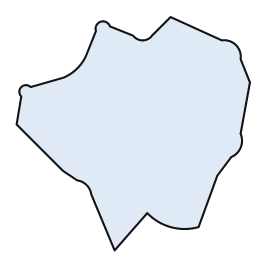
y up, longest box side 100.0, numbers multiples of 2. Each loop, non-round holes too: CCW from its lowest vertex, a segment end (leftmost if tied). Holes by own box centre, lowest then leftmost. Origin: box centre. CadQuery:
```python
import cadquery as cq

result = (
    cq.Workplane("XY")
    .moveTo(-8.0, -50.0)
    .lineTo(6.0, -34.0)
    .threePointArc((16.0, -40.0), (28.0, -40.0))
    .lineTo(36.0, -18.0)
    .lineTo(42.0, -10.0)
    .threePointArc((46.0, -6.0), (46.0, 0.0))
    .lineTo(50.0, 22.0)
    .lineTo(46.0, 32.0)
    .threePointArc((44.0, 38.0), (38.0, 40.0))
    .lineTo(16.0, 50.0)
    .lineTo(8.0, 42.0)
    .threePointArc((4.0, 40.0), (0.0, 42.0))
    .lineTo(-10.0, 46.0)
    .threePointArc((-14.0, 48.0), (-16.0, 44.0))
    .lineTo(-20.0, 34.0)
    .threePointArc((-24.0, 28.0), (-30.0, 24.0))
    .lineTo(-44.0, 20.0)
    .threePointArc((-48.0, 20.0), (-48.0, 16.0))
    .lineTo(-50.0, 4.0)
    .lineTo(-30.0, -16.0)
    .lineTo(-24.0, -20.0)
    .threePointArc((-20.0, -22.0), (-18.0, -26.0))
    .close()
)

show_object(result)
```